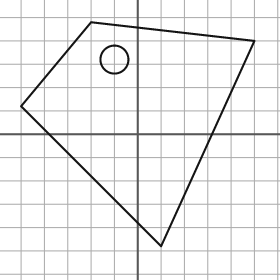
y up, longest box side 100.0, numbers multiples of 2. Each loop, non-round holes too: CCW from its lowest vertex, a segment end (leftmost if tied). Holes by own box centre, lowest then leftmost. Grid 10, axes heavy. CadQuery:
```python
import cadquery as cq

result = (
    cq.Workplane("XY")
    .moveTo(10.0, -48.0)
    .lineTo(50.0, 40.0)
    .lineTo(-20.0, 48.0)
    .lineTo(-50.0, 12.0)
    .close()
    .moveTo(-10.0, 32.0)
    .circle(6.0)
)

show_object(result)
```